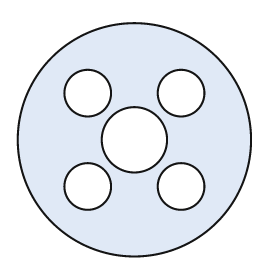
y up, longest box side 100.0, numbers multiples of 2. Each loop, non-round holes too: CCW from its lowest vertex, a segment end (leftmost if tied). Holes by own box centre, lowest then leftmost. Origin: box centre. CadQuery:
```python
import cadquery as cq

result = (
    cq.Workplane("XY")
    .moveTo(0.0, 0.0)
    .circle(50.0)
    .moveTo(-20.0, -20.0)
    .circle(10.0)
    .moveTo(20.0, -20.0)
    .circle(10.0)
    .moveTo(0.0, 0.0)
    .circle(14.0)
    .moveTo(-20.0, 20.0)
    .circle(10.0)
    .moveTo(20.0, 20.0)
    .circle(10.0)
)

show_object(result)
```